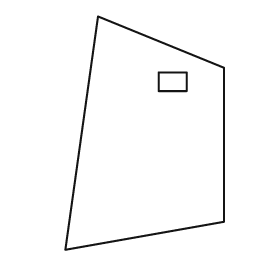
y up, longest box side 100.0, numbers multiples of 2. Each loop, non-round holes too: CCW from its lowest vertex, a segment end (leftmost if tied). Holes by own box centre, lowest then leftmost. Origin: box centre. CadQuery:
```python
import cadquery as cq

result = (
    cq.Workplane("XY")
    .moveTo(-34.0, -50.0)
    .lineTo(34.0, -38.0)
    .lineTo(34.0, 28.0)
    .lineTo(-20.0, 50.0)
    .close()
    .moveTo(6.0, 18.0)
    .lineTo(18.0, 18.0)
    .lineTo(18.0, 26.0)
    .lineTo(6.0, 26.0)
    .close()
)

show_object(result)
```